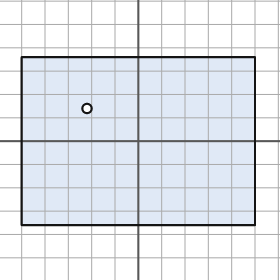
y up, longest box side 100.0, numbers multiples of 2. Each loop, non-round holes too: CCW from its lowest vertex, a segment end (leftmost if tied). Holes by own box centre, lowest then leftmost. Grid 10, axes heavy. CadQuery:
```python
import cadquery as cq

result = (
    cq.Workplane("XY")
    .moveTo(-50.0, -36.0)
    .lineTo(50.0, -36.0)
    .lineTo(50.0, 36.0)
    .lineTo(-50.0, 36.0)
    .close()
    .moveTo(-22.0, 14.0)
    .circle(2.0)
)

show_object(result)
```